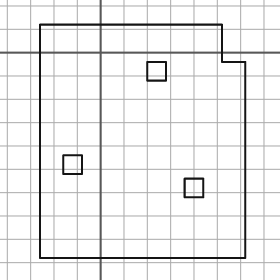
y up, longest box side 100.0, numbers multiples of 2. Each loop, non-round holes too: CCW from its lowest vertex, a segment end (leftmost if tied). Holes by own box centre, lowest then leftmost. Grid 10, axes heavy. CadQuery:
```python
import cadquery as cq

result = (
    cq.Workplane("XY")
    .moveTo(-26.0, -88.0)
    .lineTo(62.0, -88.0)
    .lineTo(62.0, -4.0)
    .lineTo(52.0, -4.0)
    .lineTo(52.0, 12.0)
    .lineTo(-26.0, 12.0)
    .close()
    .moveTo(36.0, -62.0)
    .lineTo(44.0, -62.0)
    .lineTo(44.0, -54.0)
    .lineTo(36.0, -54.0)
    .close()
    .moveTo(-16.0, -52.0)
    .lineTo(-8.0, -52.0)
    .lineTo(-8.0, -44.0)
    .lineTo(-16.0, -44.0)
    .close()
    .moveTo(20.0, -12.0)
    .lineTo(28.0, -12.0)
    .lineTo(28.0, -4.0)
    .lineTo(20.0, -4.0)
    .close()
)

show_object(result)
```